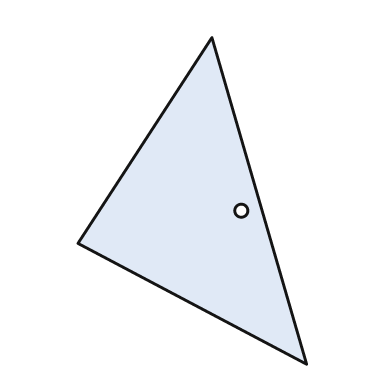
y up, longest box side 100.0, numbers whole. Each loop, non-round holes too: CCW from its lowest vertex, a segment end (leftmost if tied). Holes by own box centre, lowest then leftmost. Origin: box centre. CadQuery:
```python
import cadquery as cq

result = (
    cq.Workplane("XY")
    .moveTo(35.0, -50.0)
    .lineTo(6.0, 50.0)
    .lineTo(-35.0, -13.0)
    .close()
    .moveTo(15.0, -3.0)
    .circle(2.0)
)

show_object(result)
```